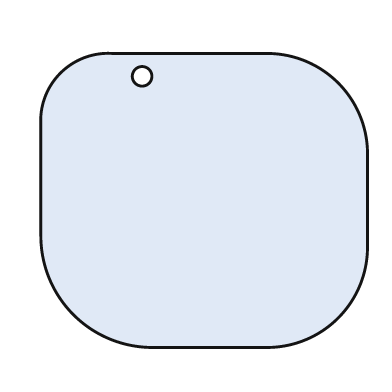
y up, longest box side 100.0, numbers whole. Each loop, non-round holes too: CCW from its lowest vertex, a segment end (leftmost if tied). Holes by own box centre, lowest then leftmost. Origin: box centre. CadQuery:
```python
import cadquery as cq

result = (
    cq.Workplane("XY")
    .moveTo(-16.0, -45.0)
    .lineTo(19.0, -45.0)
    .threePointArc((41.0, -36.0), (50.0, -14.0))
    .lineTo(50.0, 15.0)
    .threePointArc((41.0, 36.0), (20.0, 45.0))
    .lineTo(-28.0, 45.0)
    .threePointArc((-44.0, 39.0), (-50.0, 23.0))
    .lineTo(-50.0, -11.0)
    .threePointArc((-40.0, -35.0), (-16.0, -45.0))
    .close()
    .moveTo(-19.0, 38.0)
    .circle(3.0)
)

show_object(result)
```